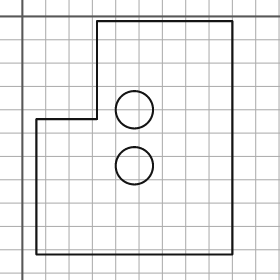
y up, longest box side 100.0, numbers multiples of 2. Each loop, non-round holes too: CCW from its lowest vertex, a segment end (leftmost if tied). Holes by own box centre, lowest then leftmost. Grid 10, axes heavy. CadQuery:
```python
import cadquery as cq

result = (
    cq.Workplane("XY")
    .moveTo(6.0, -102.0)
    .lineTo(90.0, -102.0)
    .lineTo(90.0, -2.0)
    .lineTo(32.0, -2.0)
    .lineTo(32.0, -44.0)
    .lineTo(6.0, -44.0)
    .close()
    .moveTo(48.0, -64.0)
    .circle(8.0)
    .moveTo(48.0, -40.0)
    .circle(8.0)
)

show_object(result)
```